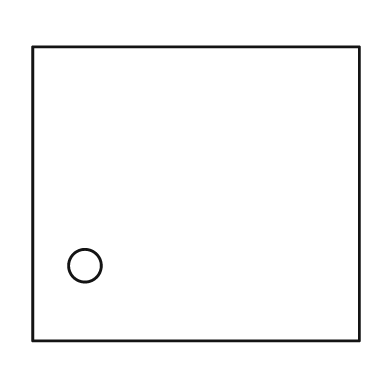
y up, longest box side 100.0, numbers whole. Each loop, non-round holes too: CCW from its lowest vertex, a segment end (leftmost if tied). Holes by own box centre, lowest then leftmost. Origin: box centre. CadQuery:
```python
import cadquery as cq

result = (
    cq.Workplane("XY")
    .moveTo(-50.0, -45.0)
    .lineTo(50.0, -45.0)
    .lineTo(50.0, 45.0)
    .lineTo(-50.0, 45.0)
    .close()
    .moveTo(-34.0, -22.0)
    .circle(5.0)
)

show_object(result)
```